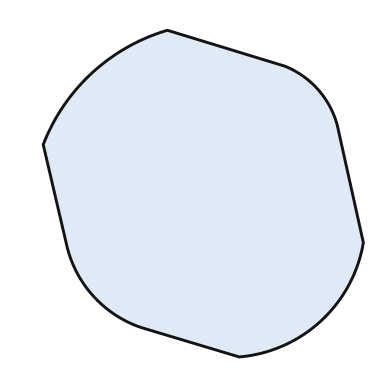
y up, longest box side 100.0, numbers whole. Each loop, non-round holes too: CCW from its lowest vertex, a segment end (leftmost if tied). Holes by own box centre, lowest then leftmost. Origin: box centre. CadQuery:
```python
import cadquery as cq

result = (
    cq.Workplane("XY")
    .moveTo(11.0, -50.0)
    .threePointArc((36.0, -39.0), (49.0, -15.0))
    .lineTo(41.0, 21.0)
    .threePointArc((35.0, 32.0), (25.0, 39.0))
    .lineTo(-11.0, 50.0)
    .threePointArc((-34.0, 37.0), (-49.0, 15.0))
    .lineTo(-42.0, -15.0)
    .threePointArc((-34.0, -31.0), (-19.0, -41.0))
    .close()
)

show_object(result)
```